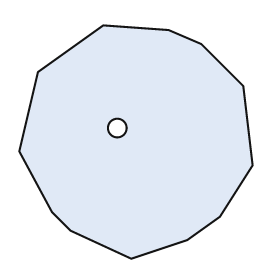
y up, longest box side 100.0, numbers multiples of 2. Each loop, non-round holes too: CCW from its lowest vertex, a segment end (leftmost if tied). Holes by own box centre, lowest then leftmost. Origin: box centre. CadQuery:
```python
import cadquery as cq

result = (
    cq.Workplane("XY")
    .moveTo(-2.0, -50.0)
    .lineTo(22.0, -42.0)
    .lineTo(36.0, -32.0)
    .lineTo(50.0, -10.0)
    .lineTo(46.0, 24.0)
    .lineTo(28.0, 42.0)
    .lineTo(14.0, 48.0)
    .lineTo(-14.0, 50.0)
    .lineTo(-42.0, 30.0)
    .lineTo(-50.0, -4.0)
    .lineTo(-36.0, -30.0)
    .lineTo(-28.0, -38.0)
    .close()
    .moveTo(-8.0, 6.0)
    .circle(4.0)
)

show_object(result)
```